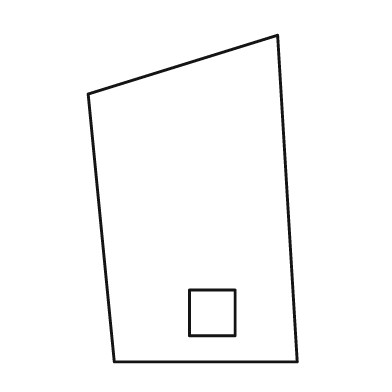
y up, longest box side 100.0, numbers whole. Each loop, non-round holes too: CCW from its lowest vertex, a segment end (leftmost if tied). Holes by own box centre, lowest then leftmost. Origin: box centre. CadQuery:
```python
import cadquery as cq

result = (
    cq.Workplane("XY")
    .moveTo(-24.0, -50.0)
    .lineTo(32.0, -50.0)
    .lineTo(26.0, 50.0)
    .lineTo(-32.0, 32.0)
    .close()
    .moveTo(-1.0, -42.0)
    .lineTo(13.0, -42.0)
    .lineTo(13.0, -28.0)
    .lineTo(-1.0, -28.0)
    .close()
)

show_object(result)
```